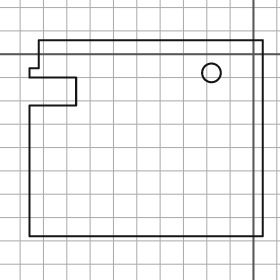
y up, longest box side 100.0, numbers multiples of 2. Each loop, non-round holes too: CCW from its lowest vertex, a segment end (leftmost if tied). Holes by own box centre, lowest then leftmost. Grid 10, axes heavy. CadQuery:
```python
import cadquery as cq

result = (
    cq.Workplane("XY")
    .moveTo(-96.0, -78.0)
    .lineTo(4.0, -78.0)
    .lineTo(4.0, 6.0)
    .lineTo(-92.0, 6.0)
    .lineTo(-92.0, -6.0)
    .lineTo(-96.0, -6.0)
    .lineTo(-96.0, -10.0)
    .lineTo(-76.0, -10.0)
    .lineTo(-76.0, -22.0)
    .lineTo(-96.0, -22.0)
    .close()
    .moveTo(-18.0, -8.0)
    .circle(4.0)
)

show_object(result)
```